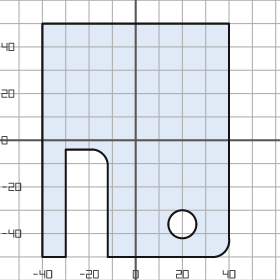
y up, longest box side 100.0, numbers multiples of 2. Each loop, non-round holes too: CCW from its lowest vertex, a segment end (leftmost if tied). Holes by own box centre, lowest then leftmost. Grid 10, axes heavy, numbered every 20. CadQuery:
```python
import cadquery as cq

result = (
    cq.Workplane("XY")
    .moveTo(-40.0, -50.0)
    .lineTo(-30.0, -50.0)
    .lineTo(-30.0, -4.0)
    .lineTo(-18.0, -4.0)
    .threePointArc((-14.0, -6.0), (-12.0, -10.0))
    .lineTo(-12.0, -50.0)
    .lineTo(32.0, -50.0)
    .threePointArc((38.0, -48.0), (40.0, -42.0))
    .lineTo(40.0, 50.0)
    .lineTo(-40.0, 50.0)
    .close()
    .moveTo(20.0, -36.0)
    .circle(6.0)
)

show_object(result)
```